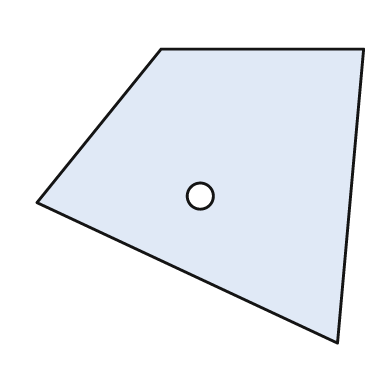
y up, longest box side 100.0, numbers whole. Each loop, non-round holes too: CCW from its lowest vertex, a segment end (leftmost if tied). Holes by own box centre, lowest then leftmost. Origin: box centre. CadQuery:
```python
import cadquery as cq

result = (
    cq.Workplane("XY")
    .moveTo(42.0, -45.0)
    .lineTo(50.0, 45.0)
    .lineTo(-12.0, 45.0)
    .lineTo(-50.0, -2.0)
    .close()
    .moveTo(0.0, 0.0)
    .circle(4.0)
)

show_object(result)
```